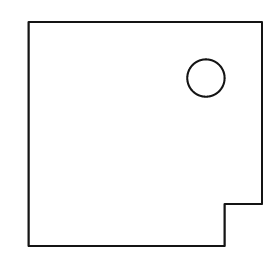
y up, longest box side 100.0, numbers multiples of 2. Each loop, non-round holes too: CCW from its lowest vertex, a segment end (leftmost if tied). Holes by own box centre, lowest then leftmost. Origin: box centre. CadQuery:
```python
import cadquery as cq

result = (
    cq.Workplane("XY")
    .moveTo(-50.0, -48.0)
    .lineTo(34.0, -48.0)
    .lineTo(34.0, -30.0)
    .lineTo(50.0, -30.0)
    .lineTo(50.0, 48.0)
    .lineTo(-50.0, 48.0)
    .close()
    .moveTo(26.0, 24.0)
    .circle(8.0)
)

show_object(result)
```